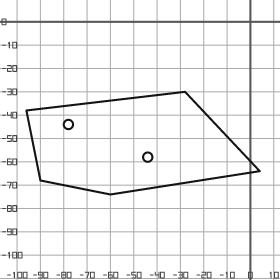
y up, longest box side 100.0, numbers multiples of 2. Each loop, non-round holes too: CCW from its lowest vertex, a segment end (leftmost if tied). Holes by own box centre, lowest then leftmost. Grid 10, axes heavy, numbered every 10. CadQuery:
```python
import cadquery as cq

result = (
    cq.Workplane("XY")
    .moveTo(-60.0, -74.0)
    .lineTo(4.0, -64.0)
    .lineTo(-28.0, -30.0)
    .lineTo(-96.0, -38.0)
    .lineTo(-90.0, -68.0)
    .close()
    .moveTo(-44.0, -58.0)
    .circle(2.0)
    .moveTo(-78.0, -44.0)
    .circle(2.0)
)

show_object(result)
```